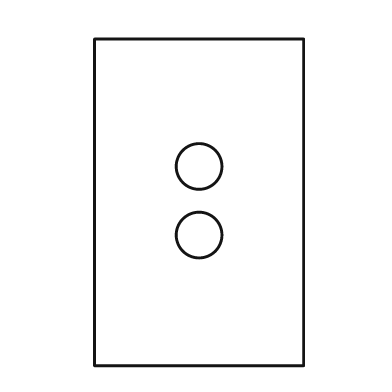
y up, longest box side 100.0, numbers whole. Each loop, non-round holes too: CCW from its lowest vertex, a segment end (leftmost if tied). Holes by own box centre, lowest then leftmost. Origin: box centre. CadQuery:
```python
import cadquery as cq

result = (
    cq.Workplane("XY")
    .moveTo(-32.0, -50.0)
    .lineTo(32.0, -50.0)
    .lineTo(32.0, 50.0)
    .lineTo(-32.0, 50.0)
    .close()
    .moveTo(0.0, -10.0)
    .circle(7.0)
    .moveTo(0.0, 11.0)
    .circle(7.0)
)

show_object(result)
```